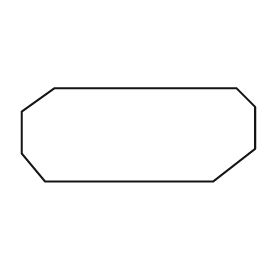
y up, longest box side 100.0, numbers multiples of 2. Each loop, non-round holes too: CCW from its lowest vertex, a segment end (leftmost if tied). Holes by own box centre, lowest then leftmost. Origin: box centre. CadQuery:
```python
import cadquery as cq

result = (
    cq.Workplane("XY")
    .moveTo(-40.0, -20.0)
    .lineTo(32.0, -20.0)
    .lineTo(50.0, -6.0)
    .lineTo(50.0, 12.0)
    .lineTo(42.0, 20.0)
    .lineTo(-36.0, 20.0)
    .lineTo(-50.0, 10.0)
    .lineTo(-50.0, -8.0)
    .close()
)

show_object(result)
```